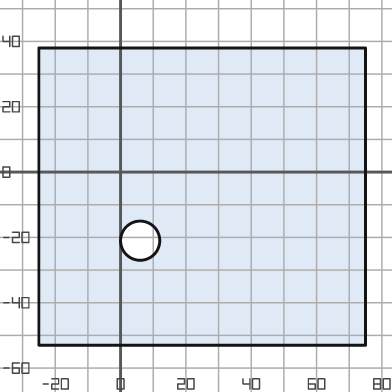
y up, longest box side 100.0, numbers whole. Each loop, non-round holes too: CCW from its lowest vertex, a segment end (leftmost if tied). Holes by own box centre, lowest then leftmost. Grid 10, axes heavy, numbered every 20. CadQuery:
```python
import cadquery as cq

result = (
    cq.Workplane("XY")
    .moveTo(-25.0, -53.0)
    .lineTo(75.0, -53.0)
    .lineTo(75.0, 38.0)
    .lineTo(-25.0, 38.0)
    .close()
    .moveTo(6.0, -21.0)
    .circle(6.0)
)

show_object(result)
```